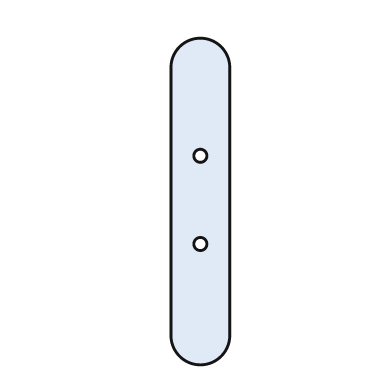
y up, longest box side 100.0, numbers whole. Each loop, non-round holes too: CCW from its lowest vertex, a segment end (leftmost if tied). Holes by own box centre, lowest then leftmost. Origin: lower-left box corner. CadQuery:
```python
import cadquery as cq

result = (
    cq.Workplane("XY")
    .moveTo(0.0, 9.0)
    .threePointArc((9.0, 0.0), (18.0, 9.0))
    .lineTo(18.0, 91.0)
    .threePointArc((9.0, 100.0), (0.0, 91.0))
    .close()
    .moveTo(9.0, 37.0)
    .circle(2.0)
    .moveTo(9.0, 64.0)
    .circle(2.0)
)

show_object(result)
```